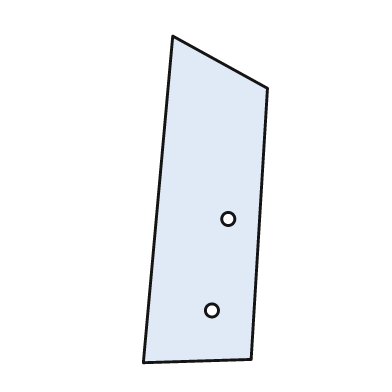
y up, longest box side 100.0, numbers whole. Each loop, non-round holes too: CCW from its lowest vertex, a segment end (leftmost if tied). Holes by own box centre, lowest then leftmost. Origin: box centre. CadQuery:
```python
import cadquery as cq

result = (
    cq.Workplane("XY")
    .moveTo(-19.0, -50.0)
    .lineTo(14.0, -49.0)
    .lineTo(19.0, 34.0)
    .lineTo(-10.0, 50.0)
    .close()
    .moveTo(2.0, -34.0)
    .circle(2.0)
    .moveTo(7.0, -6.0)
    .circle(2.0)
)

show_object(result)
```